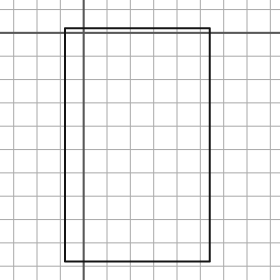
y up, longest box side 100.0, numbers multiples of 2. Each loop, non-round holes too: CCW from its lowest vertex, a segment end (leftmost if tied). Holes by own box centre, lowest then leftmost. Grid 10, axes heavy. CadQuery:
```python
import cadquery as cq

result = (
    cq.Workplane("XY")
    .moveTo(-8.0, -98.0)
    .lineTo(54.0, -98.0)
    .lineTo(54.0, 2.0)
    .lineTo(-8.0, 2.0)
    .close()
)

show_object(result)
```